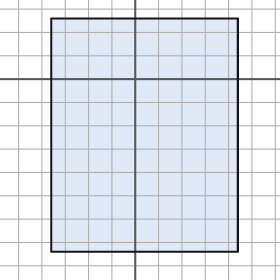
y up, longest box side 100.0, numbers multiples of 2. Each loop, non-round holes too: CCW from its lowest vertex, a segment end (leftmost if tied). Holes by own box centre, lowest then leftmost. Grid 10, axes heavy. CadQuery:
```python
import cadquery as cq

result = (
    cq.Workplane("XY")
    .moveTo(-36.0, -74.0)
    .lineTo(44.0, -74.0)
    .lineTo(44.0, 26.0)
    .lineTo(-36.0, 26.0)
    .close()
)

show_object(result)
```